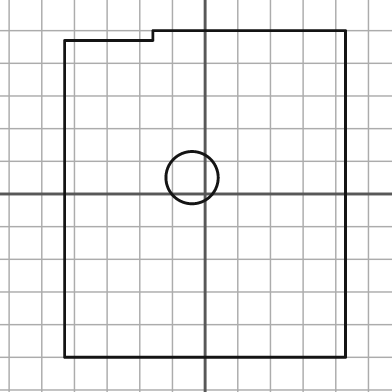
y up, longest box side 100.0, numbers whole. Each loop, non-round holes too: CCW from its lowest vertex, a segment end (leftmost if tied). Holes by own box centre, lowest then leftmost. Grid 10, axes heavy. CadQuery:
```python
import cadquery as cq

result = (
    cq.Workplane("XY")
    .moveTo(-43.0, -50.0)
    .lineTo(43.0, -50.0)
    .lineTo(43.0, 50.0)
    .lineTo(-16.0, 50.0)
    .lineTo(-16.0, 47.0)
    .lineTo(-43.0, 47.0)
    .close()
    .moveTo(-4.0, 5.0)
    .circle(8.0)
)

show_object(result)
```